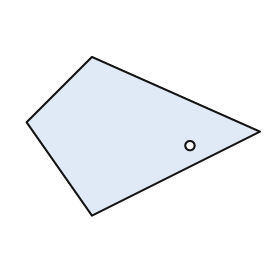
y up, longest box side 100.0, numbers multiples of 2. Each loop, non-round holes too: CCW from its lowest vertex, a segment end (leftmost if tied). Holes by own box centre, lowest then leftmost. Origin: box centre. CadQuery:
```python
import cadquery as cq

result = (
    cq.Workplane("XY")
    .moveTo(-22.0, -34.0)
    .lineTo(50.0, 2.0)
    .lineTo(-22.0, 34.0)
    .lineTo(-50.0, 6.0)
    .close()
    .moveTo(20.0, -4.0)
    .circle(2.0)
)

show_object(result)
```